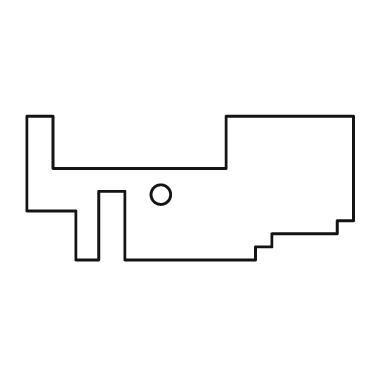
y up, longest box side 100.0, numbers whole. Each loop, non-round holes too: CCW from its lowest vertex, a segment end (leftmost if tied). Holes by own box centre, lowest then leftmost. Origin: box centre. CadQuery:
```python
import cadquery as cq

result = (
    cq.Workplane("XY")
    .moveTo(-35.0, -22.0)
    .lineTo(-28.0, -22.0)
    .lineTo(-28.0, -1.0)
    .lineTo(-20.0, -1.0)
    .lineTo(-20.0, -22.0)
    .lineTo(20.0, -22.0)
    .lineTo(20.0, -18.0)
    .lineTo(25.0, -18.0)
    .lineTo(25.0, -14.0)
    .lineTo(45.0, -14.0)
    .lineTo(45.0, -10.0)
    .lineTo(50.0, -10.0)
    .lineTo(50.0, 22.0)
    .lineTo(11.0, 22.0)
    .lineTo(11.0, 6.0)
    .lineTo(-42.0, 6.0)
    .lineTo(-42.0, 22.0)
    .lineTo(-50.0, 22.0)
    .lineTo(-50.0, -7.0)
    .lineTo(-35.0, -7.0)
    .close()
    .moveTo(-9.0, -2.0)
    .circle(3.0)
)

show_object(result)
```